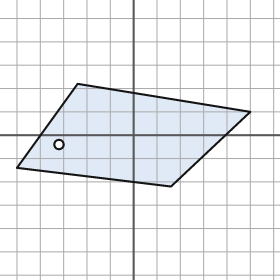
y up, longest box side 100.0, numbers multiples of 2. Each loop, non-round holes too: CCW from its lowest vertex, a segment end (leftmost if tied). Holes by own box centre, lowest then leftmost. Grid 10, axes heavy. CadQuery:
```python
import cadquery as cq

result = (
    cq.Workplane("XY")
    .moveTo(16.0, -22.0)
    .lineTo(50.0, 10.0)
    .lineTo(-24.0, 22.0)
    .lineTo(-50.0, -14.0)
    .close()
    .moveTo(-32.0, -4.0)
    .circle(2.0)
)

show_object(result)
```